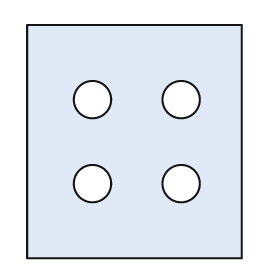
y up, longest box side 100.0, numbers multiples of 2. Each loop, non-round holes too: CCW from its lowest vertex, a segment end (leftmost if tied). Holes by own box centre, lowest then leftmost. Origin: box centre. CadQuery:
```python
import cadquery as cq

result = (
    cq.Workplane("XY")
    .moveTo(-46.0, -50.0)
    .lineTo(46.0, -50.0)
    .lineTo(46.0, 50.0)
    .lineTo(-46.0, 50.0)
    .close()
    .moveTo(-18.0, -18.0)
    .circle(8.0)
    .moveTo(20.0, -18.0)
    .circle(8.0)
    .moveTo(-18.0, 18.0)
    .circle(8.0)
    .moveTo(20.0, 18.0)
    .circle(8.0)
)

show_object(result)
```